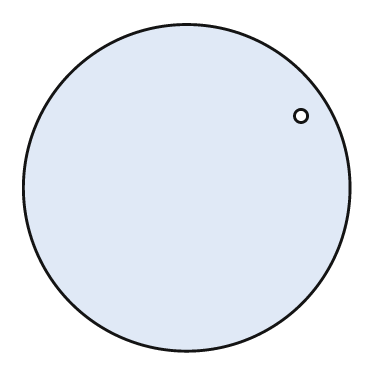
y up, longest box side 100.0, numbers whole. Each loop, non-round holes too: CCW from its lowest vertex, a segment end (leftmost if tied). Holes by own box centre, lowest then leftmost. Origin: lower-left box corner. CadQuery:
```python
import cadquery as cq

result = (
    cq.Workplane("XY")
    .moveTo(50.0, 50.0)
    .circle(50.0)
    .moveTo(85.0, 72.0)
    .circle(2.0)
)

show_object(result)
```